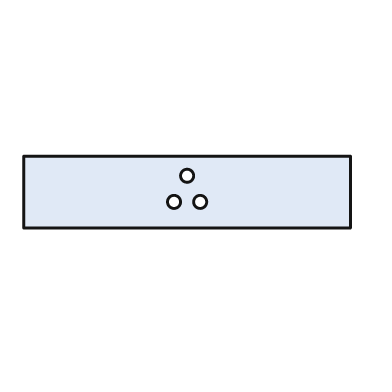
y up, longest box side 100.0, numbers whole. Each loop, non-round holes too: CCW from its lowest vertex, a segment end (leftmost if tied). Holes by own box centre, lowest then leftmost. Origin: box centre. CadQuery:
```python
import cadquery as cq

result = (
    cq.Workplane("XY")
    .moveTo(-50.0, -11.0)
    .lineTo(50.0, -11.0)
    .lineTo(50.0, 11.0)
    .lineTo(-50.0, 11.0)
    .close()
    .moveTo(-4.0, -3.0)
    .circle(2.0)
    .moveTo(4.0, -3.0)
    .circle(2.0)
    .moveTo(0.0, 5.0)
    .circle(2.0)
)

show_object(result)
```